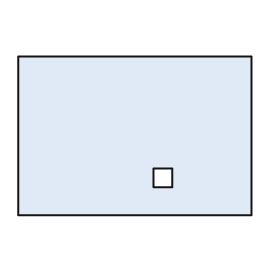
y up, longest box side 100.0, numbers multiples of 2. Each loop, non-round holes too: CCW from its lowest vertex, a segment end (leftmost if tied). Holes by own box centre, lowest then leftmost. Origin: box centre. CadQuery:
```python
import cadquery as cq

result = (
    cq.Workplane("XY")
    .moveTo(-50.0, -34.0)
    .lineTo(50.0, -34.0)
    .lineTo(50.0, 34.0)
    .lineTo(-50.0, 34.0)
    .close()
    .moveTo(8.0, -22.0)
    .lineTo(16.0, -22.0)
    .lineTo(16.0, -14.0)
    .lineTo(8.0, -14.0)
    .close()
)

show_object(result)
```